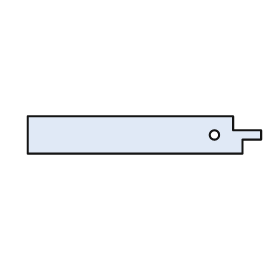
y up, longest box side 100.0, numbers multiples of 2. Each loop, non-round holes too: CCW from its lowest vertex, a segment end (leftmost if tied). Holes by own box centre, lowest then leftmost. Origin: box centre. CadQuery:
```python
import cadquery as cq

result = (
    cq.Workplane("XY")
    .moveTo(-50.0, -8.0)
    .lineTo(42.0, -8.0)
    .lineTo(42.0, -2.0)
    .lineTo(50.0, -2.0)
    .lineTo(50.0, 2.0)
    .lineTo(38.0, 2.0)
    .lineTo(38.0, 8.0)
    .lineTo(-50.0, 8.0)
    .close()
    .moveTo(30.0, 0.0)
    .circle(2.0)
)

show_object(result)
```